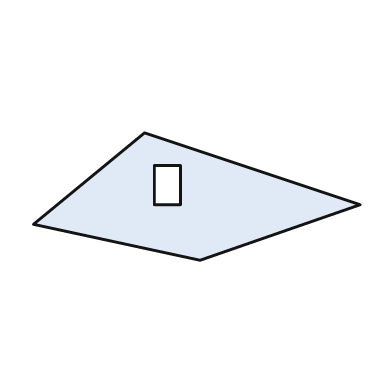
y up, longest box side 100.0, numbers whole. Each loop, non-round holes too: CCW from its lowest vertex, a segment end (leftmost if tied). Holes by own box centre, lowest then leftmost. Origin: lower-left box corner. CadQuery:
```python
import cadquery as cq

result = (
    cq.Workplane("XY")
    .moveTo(51.0, 0.0)
    .lineTo(100.0, 17.0)
    .lineTo(34.0, 39.0)
    .lineTo(0.0, 11.0)
    .close()
    .moveTo(37.0, 17.0)
    .lineTo(45.0, 17.0)
    .lineTo(45.0, 29.0)
    .lineTo(37.0, 29.0)
    .close()
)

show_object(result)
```